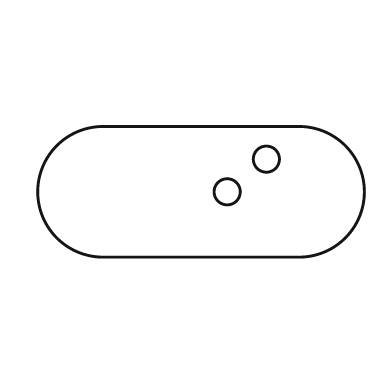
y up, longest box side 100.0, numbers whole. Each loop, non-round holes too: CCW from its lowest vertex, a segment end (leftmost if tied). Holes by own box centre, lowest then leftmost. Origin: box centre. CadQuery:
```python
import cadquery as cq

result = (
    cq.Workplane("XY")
    .moveTo(-30.0, -20.0)
    .lineTo(30.0, -20.0)
    .threePointArc((50.0, 0.0), (30.0, 20.0))
    .lineTo(-30.0, 20.0)
    .threePointArc((-50.0, 0.0), (-30.0, -20.0))
    .close()
    .moveTo(8.0, 0.0)
    .circle(4.0)
    .moveTo(20.0, 10.0)
    .circle(4.0)
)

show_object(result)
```